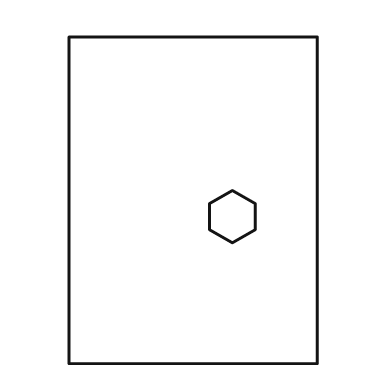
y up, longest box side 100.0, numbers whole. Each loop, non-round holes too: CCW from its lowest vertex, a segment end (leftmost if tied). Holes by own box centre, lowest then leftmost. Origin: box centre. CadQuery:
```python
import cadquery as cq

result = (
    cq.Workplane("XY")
    .moveTo(-38.0, -50.0)
    .lineTo(38.0, -50.0)
    .lineTo(38.0, 50.0)
    .lineTo(-38.0, 50.0)
    .close()
    .moveTo(12.0, -13.0)
    .lineTo(19.0, -9.0)
    .lineTo(19.0, -1.0)
    .lineTo(12.0, 3.0)
    .lineTo(5.0, -1.0)
    .lineTo(5.0, -9.0)
    .close()
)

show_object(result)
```